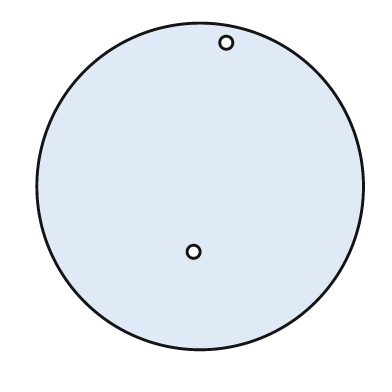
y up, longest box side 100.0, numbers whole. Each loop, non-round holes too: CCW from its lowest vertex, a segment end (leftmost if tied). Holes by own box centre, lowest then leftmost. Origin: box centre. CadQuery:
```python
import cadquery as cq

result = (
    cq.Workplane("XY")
    .moveTo(0.0, 0.0)
    .circle(50.0)
    .moveTo(-2.0, -20.0)
    .circle(2.0)
    .moveTo(8.0, 44.0)
    .circle(2.0)
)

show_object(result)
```